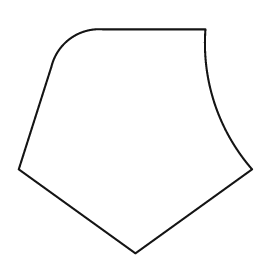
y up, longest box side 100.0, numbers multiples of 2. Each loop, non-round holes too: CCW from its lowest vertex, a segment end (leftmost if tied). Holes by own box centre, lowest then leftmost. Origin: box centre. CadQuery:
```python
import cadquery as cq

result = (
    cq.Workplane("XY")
    .moveTo(0.0, -48.0)
    .lineTo(50.0, -12.0)
    .threePointArc((34.0, 16.0), (30.0, 48.0))
    .lineTo(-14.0, 48.0)
    .threePointArc((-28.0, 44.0), (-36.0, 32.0))
    .lineTo(-50.0, -12.0)
    .close()
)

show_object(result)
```